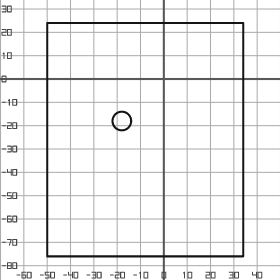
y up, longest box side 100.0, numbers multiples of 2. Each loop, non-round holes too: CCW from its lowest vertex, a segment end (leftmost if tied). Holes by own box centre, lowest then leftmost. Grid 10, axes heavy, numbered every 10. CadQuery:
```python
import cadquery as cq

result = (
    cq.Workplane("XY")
    .moveTo(-50.0, -76.0)
    .lineTo(34.0, -76.0)
    .lineTo(34.0, 24.0)
    .lineTo(-50.0, 24.0)
    .close()
    .moveTo(-18.0, -18.0)
    .circle(4.0)
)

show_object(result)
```